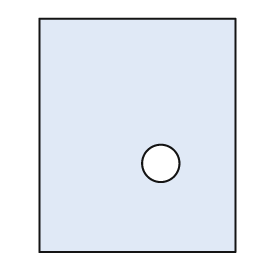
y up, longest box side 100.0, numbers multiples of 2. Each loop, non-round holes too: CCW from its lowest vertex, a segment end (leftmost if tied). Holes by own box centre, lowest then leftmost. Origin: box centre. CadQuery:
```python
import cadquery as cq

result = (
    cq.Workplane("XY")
    .moveTo(-42.0, -50.0)
    .lineTo(42.0, -50.0)
    .lineTo(42.0, 50.0)
    .lineTo(-42.0, 50.0)
    .close()
    .moveTo(10.0, -12.0)
    .circle(8.0)
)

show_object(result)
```